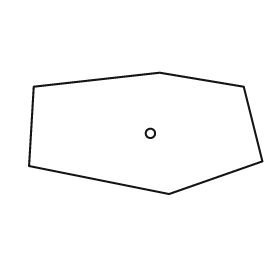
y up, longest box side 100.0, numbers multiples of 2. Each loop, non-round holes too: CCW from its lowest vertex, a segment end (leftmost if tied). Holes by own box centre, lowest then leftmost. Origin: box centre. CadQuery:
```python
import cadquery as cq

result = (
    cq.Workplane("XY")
    .moveTo(10.0, -26.0)
    .lineTo(50.0, -12.0)
    .lineTo(42.0, 20.0)
    .lineTo(6.0, 26.0)
    .lineTo(-48.0, 20.0)
    .lineTo(-50.0, -14.0)
    .close()
    .moveTo(2.0, 0.0)
    .circle(2.0)
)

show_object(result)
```